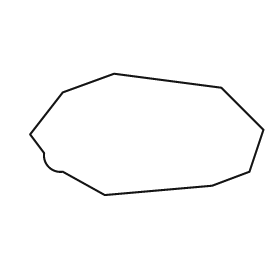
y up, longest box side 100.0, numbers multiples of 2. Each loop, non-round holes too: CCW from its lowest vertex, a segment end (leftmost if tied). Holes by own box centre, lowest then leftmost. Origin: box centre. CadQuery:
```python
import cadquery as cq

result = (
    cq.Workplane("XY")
    .moveTo(-18.0, -26.0)
    .lineTo(28.0, -22.0)
    .lineTo(44.0, -16.0)
    .lineTo(50.0, 2.0)
    .lineTo(32.0, 20.0)
    .lineTo(-14.0, 26.0)
    .lineTo(-36.0, 18.0)
    .lineTo(-50.0, 0.0)
    .lineTo(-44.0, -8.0)
    .threePointArc((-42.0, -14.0), (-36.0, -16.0))
    .close()
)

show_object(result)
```